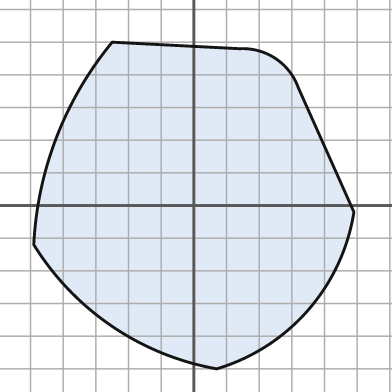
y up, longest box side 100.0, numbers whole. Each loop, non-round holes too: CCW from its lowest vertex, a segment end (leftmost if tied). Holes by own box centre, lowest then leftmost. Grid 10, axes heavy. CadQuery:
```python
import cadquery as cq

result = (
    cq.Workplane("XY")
    .moveTo(7.0, -50.0)
    .threePointArc((35.0, -32.0), (49.0, -2.0))
    .lineTo(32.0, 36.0)
    .threePointArc((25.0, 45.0), (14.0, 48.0))
    .lineTo(-25.0, 50.0)
    .threePointArc((-42.0, 21.0), (-49.0, -12.0))
    .threePointArc((-25.0, -37.0), (7.0, -50.0))
    .close()
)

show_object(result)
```